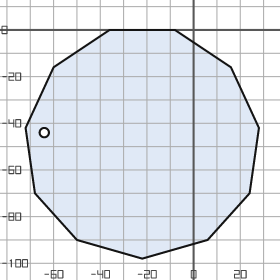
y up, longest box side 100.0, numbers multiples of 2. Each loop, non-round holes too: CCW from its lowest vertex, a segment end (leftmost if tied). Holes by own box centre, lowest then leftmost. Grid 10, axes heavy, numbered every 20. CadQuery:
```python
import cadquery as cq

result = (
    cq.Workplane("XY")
    .moveTo(-22.0, -98.0)
    .lineTo(6.0, -90.0)
    .lineTo(24.0, -70.0)
    .lineTo(28.0, -42.0)
    .lineTo(16.0, -16.0)
    .lineTo(-8.0, 0.0)
    .lineTo(-36.0, 0.0)
    .lineTo(-60.0, -16.0)
    .lineTo(-72.0, -42.0)
    .lineTo(-68.0, -70.0)
    .lineTo(-50.0, -90.0)
    .close()
    .moveTo(-64.0, -44.0)
    .circle(2.0)
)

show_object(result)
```